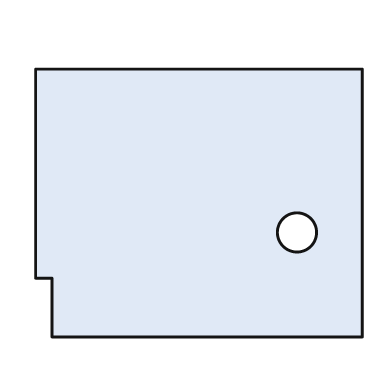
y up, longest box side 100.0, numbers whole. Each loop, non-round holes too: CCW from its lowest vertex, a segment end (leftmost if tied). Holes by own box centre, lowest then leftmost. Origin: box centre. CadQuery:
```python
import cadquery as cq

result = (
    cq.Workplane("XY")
    .moveTo(-45.0, -41.0)
    .lineTo(50.0, -41.0)
    .lineTo(50.0, 41.0)
    .lineTo(-50.0, 41.0)
    .lineTo(-50.0, -23.0)
    .lineTo(-45.0, -23.0)
    .close()
    .moveTo(30.0, -9.0)
    .circle(6.0)
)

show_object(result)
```